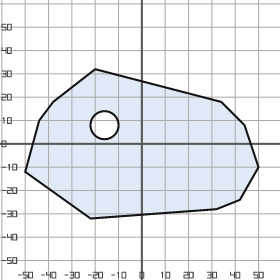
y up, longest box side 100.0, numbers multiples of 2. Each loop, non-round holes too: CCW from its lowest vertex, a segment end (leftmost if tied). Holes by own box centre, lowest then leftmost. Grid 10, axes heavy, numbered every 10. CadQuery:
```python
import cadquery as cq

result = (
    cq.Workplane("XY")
    .moveTo(-22.0, -32.0)
    .lineTo(32.0, -28.0)
    .lineTo(42.0, -24.0)
    .lineTo(50.0, -10.0)
    .lineTo(44.0, 8.0)
    .lineTo(34.0, 18.0)
    .lineTo(-20.0, 32.0)
    .lineTo(-38.0, 18.0)
    .lineTo(-44.0, 10.0)
    .lineTo(-50.0, -12.0)
    .close()
    .moveTo(-16.0, 8.0)
    .circle(6.0)
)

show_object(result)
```